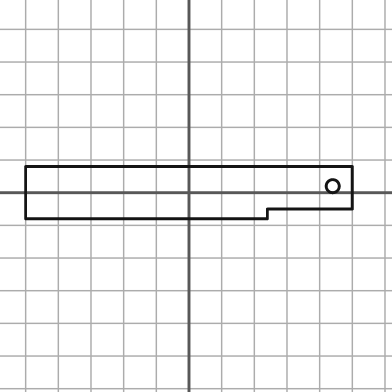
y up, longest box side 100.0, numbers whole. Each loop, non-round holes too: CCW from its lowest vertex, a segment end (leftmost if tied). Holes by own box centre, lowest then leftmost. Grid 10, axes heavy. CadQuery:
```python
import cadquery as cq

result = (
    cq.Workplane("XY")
    .moveTo(-50.0, -8.0)
    .lineTo(24.0, -8.0)
    .lineTo(24.0, -5.0)
    .lineTo(50.0, -5.0)
    .lineTo(50.0, 8.0)
    .lineTo(-50.0, 8.0)
    .close()
    .moveTo(44.0, 2.0)
    .circle(2.0)
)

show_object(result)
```